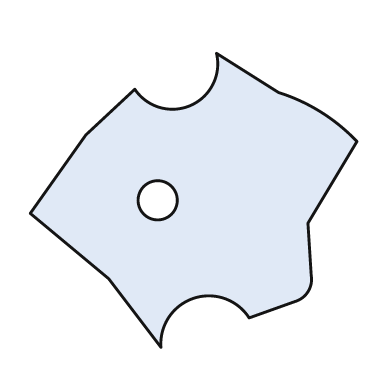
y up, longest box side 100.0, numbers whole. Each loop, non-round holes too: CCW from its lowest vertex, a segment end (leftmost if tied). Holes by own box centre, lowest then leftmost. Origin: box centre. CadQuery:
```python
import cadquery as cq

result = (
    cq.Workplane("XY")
    .moveTo(-10.0, -45.0)
    .threePointArc((0.0, -30.0), (17.0, -36.0))
    .lineTo(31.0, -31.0)
    .threePointArc((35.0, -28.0), (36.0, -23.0))
    .lineTo(35.0, -7.0)
    .lineTo(50.0, 18.0)
    .threePointArc((39.0, 27.0), (26.0, 33.0))
    .lineTo(7.0, 45.0)
    .threePointArc((-1.0, 29.0), (-18.0, 34.0))
    .lineTo(-33.0, 20.0)
    .lineTo(-50.0, -4.0)
    .lineTo(-26.0, -24.0)
    .close()
    .moveTo(-11.0, 0.0)
    .circle(6.0)
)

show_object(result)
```